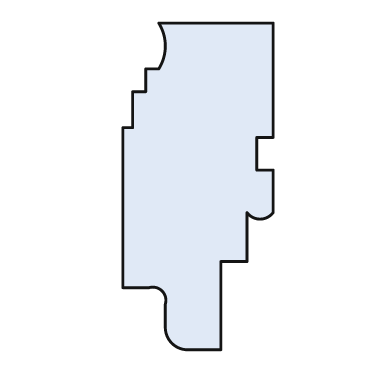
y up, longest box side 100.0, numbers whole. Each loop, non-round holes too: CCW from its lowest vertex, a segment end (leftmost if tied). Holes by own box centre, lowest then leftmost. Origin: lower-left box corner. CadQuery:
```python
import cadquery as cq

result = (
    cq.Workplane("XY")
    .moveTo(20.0, 0.0)
    .lineTo(30.0, 0.0)
    .lineTo(30.0, 27.0)
    .lineTo(38.0, 27.0)
    .lineTo(38.0, 42.0)
    .threePointArc((42.0, 40.0), (46.0, 42.0))
    .lineTo(46.0, 55.0)
    .lineTo(41.0, 55.0)
    .lineTo(41.0, 65.0)
    .lineTo(46.0, 65.0)
    .lineTo(46.0, 100.0)
    .lineTo(11.0, 100.0)
    .threePointArc((13.0, 93.0), (11.0, 86.0))
    .lineTo(7.0, 86.0)
    .lineTo(7.0, 79.0)
    .lineTo(3.0, 79.0)
    .lineTo(3.0, 68.0)
    .lineTo(0.0, 68.0)
    .lineTo(0.0, 19.0)
    .lineTo(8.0, 19.0)
    .threePointArc((12.0, 18.0), (13.0, 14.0))
    .lineTo(13.0, 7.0)
    .threePointArc((15.0, 2.0), (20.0, 0.0))
    .close()
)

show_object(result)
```